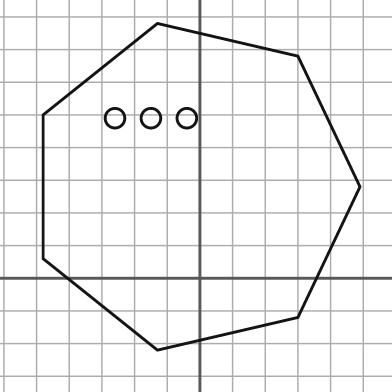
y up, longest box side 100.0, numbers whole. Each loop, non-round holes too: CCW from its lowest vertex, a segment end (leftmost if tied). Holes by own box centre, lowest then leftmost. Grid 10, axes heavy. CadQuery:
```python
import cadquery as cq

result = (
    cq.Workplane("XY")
    .moveTo(-13.0, -22.0)
    .lineTo(30.0, -12.0)
    .lineTo(49.0, 28.0)
    .lineTo(30.0, 68.0)
    .lineTo(-13.0, 78.0)
    .lineTo(-48.0, 50.0)
    .lineTo(-48.0, 6.0)
    .close()
    .moveTo(-26.0, 49.0)
    .circle(3.0)
    .moveTo(-15.0, 49.0)
    .circle(3.0)
    .moveTo(-4.0, 49.0)
    .circle(3.0)
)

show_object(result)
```